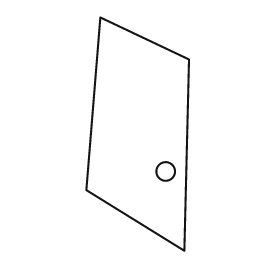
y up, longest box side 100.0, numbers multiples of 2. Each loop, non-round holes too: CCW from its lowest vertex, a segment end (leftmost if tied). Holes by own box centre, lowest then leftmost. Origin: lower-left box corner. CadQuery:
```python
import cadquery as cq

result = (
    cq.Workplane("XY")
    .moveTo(42.0, 0.0)
    .lineTo(44.0, 82.0)
    .lineTo(6.0, 100.0)
    .lineTo(0.0, 26.0)
    .close()
    .moveTo(34.0, 34.0)
    .circle(4.0)
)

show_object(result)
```